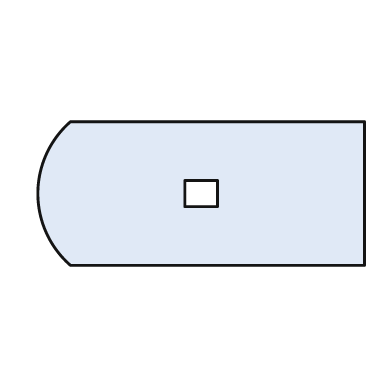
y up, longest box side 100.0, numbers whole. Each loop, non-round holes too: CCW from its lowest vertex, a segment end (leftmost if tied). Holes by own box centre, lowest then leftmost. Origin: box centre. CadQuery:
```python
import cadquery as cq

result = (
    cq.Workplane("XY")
    .moveTo(-40.0, -22.0)
    .lineTo(50.0, -22.0)
    .lineTo(50.0, 22.0)
    .lineTo(-40.0, 22.0)
    .threePointArc((-50.0, 0.0), (-40.0, -22.0))
    .close()
    .moveTo(-5.0, -4.0)
    .lineTo(5.0, -4.0)
    .lineTo(5.0, 4.0)
    .lineTo(-5.0, 4.0)
    .close()
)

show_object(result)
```